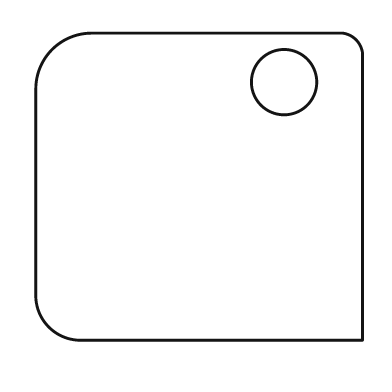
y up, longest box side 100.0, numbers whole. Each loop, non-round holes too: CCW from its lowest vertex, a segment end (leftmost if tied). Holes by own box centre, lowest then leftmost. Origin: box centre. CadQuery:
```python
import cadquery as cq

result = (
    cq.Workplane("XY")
    .moveTo(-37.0, -47.0)
    .lineTo(50.0, -47.0)
    .lineTo(50.0, 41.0)
    .threePointArc((48.0, 45.0), (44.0, 47.0))
    .lineTo(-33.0, 47.0)
    .threePointArc((-45.0, 42.0), (-50.0, 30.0))
    .lineTo(-50.0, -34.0)
    .threePointArc((-46.0, -43.0), (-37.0, -47.0))
    .close()
    .moveTo(26.0, 32.0)
    .circle(10.0)
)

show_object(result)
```